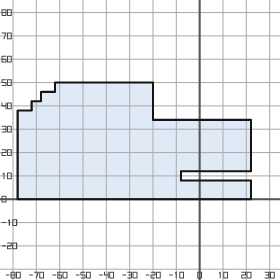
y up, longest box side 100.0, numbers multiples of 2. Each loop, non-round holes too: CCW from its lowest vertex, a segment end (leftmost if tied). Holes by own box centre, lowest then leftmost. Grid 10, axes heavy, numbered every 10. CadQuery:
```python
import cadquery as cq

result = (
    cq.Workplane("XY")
    .moveTo(-78.0, 0.0)
    .lineTo(22.0, 0.0)
    .lineTo(22.0, 8.0)
    .lineTo(-8.0, 8.0)
    .lineTo(-8.0, 12.0)
    .lineTo(22.0, 12.0)
    .lineTo(22.0, 34.0)
    .lineTo(-20.0, 34.0)
    .lineTo(-20.0, 50.0)
    .lineTo(-62.0, 50.0)
    .lineTo(-62.0, 46.0)
    .lineTo(-68.0, 46.0)
    .lineTo(-68.0, 42.0)
    .lineTo(-72.0, 42.0)
    .lineTo(-72.0, 38.0)
    .lineTo(-78.0, 38.0)
    .close()
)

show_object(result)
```